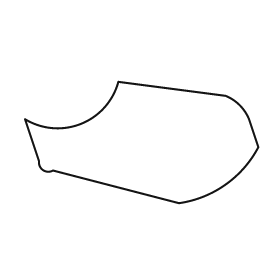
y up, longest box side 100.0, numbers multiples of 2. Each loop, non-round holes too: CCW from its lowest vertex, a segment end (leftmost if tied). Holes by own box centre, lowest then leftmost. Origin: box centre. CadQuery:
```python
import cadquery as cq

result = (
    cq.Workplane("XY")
    .moveTo(16.0, -26.0)
    .threePointArc((36.0, -18.0), (50.0, -2.0))
    .lineTo(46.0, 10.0)
    .threePointArc((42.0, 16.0), (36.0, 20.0))
    .lineTo(-10.0, 26.0)
    .threePointArc((-26.0, 8.0), (-50.0, 10.0))
    .lineTo(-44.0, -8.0)
    .threePointArc((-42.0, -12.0), (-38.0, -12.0))
    .close()
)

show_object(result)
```